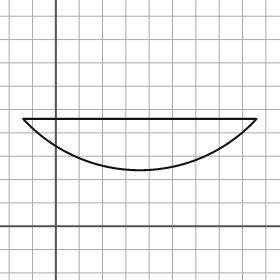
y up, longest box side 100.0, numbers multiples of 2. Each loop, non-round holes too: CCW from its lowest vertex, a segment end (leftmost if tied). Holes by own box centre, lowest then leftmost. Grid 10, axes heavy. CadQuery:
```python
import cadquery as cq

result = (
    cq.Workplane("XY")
    .moveTo(-14.0, 46.0)
    .threePointArc((36.0, 24.0), (86.0, 46.0))
    .close()
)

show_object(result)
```